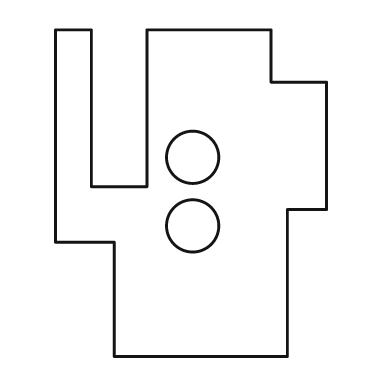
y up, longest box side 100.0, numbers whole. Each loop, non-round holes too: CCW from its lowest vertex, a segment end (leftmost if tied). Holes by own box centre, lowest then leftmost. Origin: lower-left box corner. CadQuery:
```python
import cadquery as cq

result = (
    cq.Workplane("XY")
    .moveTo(18.0, 0.0)
    .lineTo(71.0, 0.0)
    .lineTo(71.0, 45.0)
    .lineTo(83.0, 45.0)
    .lineTo(83.0, 84.0)
    .lineTo(66.0, 84.0)
    .lineTo(66.0, 100.0)
    .lineTo(28.0, 100.0)
    .lineTo(28.0, 52.0)
    .lineTo(11.0, 52.0)
    .lineTo(11.0, 100.0)
    .lineTo(0.0, 100.0)
    .lineTo(0.0, 35.0)
    .lineTo(18.0, 35.0)
    .close()
    .moveTo(42.0, 40.0)
    .circle(8.0)
    .moveTo(42.0, 61.0)
    .circle(8.0)
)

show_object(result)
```